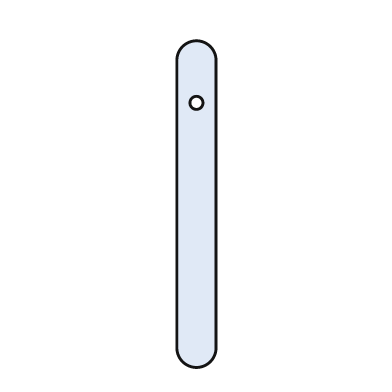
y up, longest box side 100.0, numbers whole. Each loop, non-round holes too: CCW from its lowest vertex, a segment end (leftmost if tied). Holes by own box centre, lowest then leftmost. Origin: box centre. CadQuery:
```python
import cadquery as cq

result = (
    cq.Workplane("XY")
    .moveTo(-6.0, -44.0)
    .threePointArc((0.0, -50.0), (6.0, -44.0))
    .lineTo(6.0, 44.0)
    .threePointArc((0.0, 50.0), (-6.0, 44.0))
    .close()
    .moveTo(0.0, 31.0)
    .circle(2.0)
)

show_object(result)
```